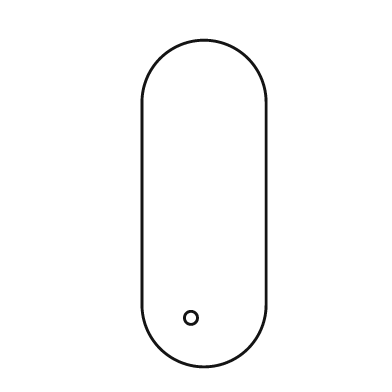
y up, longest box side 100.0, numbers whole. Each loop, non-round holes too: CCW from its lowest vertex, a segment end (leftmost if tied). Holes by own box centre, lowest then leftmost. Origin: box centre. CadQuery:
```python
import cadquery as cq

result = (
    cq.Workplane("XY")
    .moveTo(-19.0, -31.0)
    .threePointArc((0.0, -50.0), (19.0, -31.0))
    .lineTo(19.0, 31.0)
    .threePointArc((0.0, 50.0), (-19.0, 31.0))
    .close()
    .moveTo(-4.0, -35.0)
    .circle(2.0)
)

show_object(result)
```